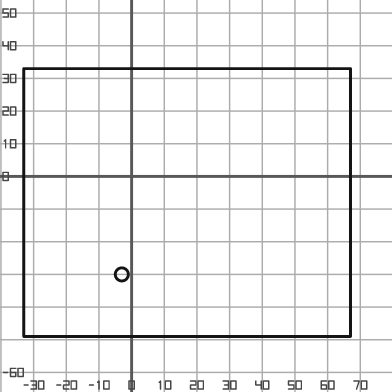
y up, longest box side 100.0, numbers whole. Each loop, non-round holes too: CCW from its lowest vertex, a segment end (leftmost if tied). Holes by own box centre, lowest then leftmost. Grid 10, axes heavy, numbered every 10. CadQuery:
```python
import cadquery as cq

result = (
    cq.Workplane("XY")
    .moveTo(-33.0, -49.0)
    .lineTo(67.0, -49.0)
    .lineTo(67.0, 33.0)
    .lineTo(-33.0, 33.0)
    .close()
    .moveTo(-3.0, -30.0)
    .circle(2.0)
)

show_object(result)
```